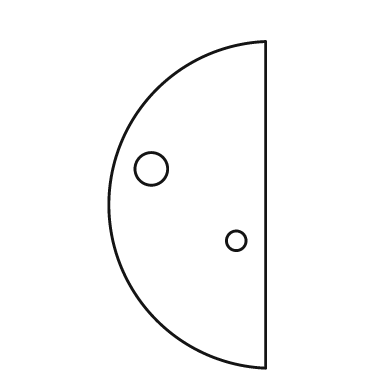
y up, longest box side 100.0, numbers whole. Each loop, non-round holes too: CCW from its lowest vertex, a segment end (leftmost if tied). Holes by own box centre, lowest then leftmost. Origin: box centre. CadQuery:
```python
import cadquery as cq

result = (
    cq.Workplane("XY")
    .moveTo(24.0, -50.0)
    .lineTo(24.0, 50.0)
    .threePointArc((-24.0, 0.0), (24.0, -50.0))
    .close()
    .moveTo(15.0, -11.0)
    .circle(3.0)
    .moveTo(-11.0, 11.0)
    .circle(5.0)
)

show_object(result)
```